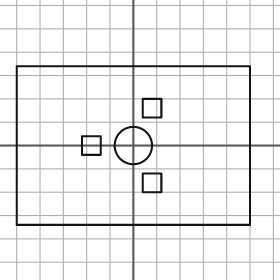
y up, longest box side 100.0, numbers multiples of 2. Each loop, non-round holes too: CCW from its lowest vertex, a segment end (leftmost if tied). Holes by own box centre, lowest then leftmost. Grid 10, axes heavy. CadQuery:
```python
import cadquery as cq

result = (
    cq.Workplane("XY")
    .moveTo(-50.0, -34.0)
    .lineTo(50.0, -34.0)
    .lineTo(50.0, 34.0)
    .lineTo(-50.0, 34.0)
    .close()
    .moveTo(4.0, -20.0)
    .lineTo(12.0, -20.0)
    .lineTo(12.0, -12.0)
    .lineTo(4.0, -12.0)
    .close()
    .moveTo(-22.0, -4.0)
    .lineTo(-14.0, -4.0)
    .lineTo(-14.0, 4.0)
    .lineTo(-22.0, 4.0)
    .close()
    .moveTo(0.0, 0.0)
    .circle(8.0)
    .moveTo(4.0, 12.0)
    .lineTo(12.0, 12.0)
    .lineTo(12.0, 20.0)
    .lineTo(4.0, 20.0)
    .close()
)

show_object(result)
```